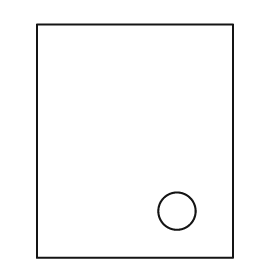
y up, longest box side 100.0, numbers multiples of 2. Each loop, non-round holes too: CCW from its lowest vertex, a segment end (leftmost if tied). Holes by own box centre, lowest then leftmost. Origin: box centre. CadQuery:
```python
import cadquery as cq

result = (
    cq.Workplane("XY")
    .moveTo(-42.0, -50.0)
    .lineTo(42.0, -50.0)
    .lineTo(42.0, 50.0)
    .lineTo(-42.0, 50.0)
    .close()
    .moveTo(18.0, -30.0)
    .circle(8.0)
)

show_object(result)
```